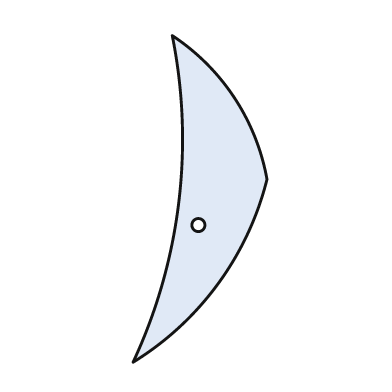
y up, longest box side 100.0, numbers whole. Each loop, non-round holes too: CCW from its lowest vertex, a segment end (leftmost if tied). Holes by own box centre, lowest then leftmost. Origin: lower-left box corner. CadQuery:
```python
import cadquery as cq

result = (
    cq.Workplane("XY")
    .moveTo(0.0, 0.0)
    .threePointArc((26.0, 24.0), (41.0, 56.0))
    .threePointArc((31.0, 81.0), (12.0, 100.0))
    .threePointArc((14.0, 49.0), (0.0, 0.0))
    .close()
    .moveTo(20.0, 42.0)
    .circle(2.0)
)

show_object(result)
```